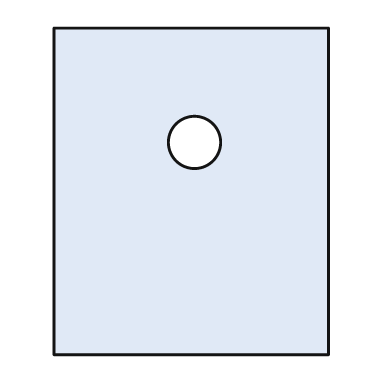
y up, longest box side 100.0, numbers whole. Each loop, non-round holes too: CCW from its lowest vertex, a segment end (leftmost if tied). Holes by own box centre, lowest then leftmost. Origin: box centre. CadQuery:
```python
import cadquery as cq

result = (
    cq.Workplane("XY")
    .moveTo(-42.0, -50.0)
    .lineTo(42.0, -50.0)
    .lineTo(42.0, 50.0)
    .lineTo(-42.0, 50.0)
    .close()
    .moveTo(1.0, 15.0)
    .circle(8.0)
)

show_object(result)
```